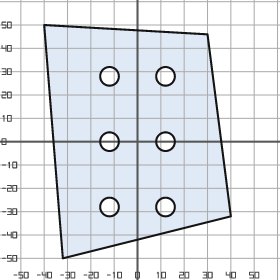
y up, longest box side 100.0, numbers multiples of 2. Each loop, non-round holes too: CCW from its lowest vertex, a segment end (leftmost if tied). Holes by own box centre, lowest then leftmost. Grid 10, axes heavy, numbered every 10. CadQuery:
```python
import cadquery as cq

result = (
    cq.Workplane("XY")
    .moveTo(-32.0, -50.0)
    .lineTo(40.0, -32.0)
    .lineTo(30.0, 46.0)
    .lineTo(-40.0, 50.0)
    .close()
    .moveTo(-12.0, -28.0)
    .circle(4.0)
    .moveTo(12.0, -28.0)
    .circle(4.0)
    .moveTo(-12.0, 0.0)
    .circle(4.0)
    .moveTo(12.0, 0.0)
    .circle(4.0)
    .moveTo(-12.0, 28.0)
    .circle(4.0)
    .moveTo(12.0, 28.0)
    .circle(4.0)
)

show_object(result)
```